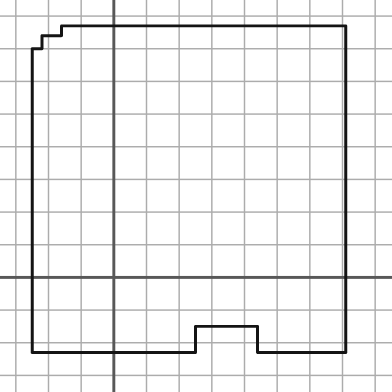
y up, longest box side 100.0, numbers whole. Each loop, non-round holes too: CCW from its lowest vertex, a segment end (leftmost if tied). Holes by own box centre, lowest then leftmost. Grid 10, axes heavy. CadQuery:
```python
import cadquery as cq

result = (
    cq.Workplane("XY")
    .moveTo(-25.0, -23.0)
    .lineTo(25.0, -23.0)
    .lineTo(25.0, -15.0)
    .lineTo(44.0, -15.0)
    .lineTo(44.0, -23.0)
    .lineTo(71.0, -23.0)
    .lineTo(71.0, 77.0)
    .lineTo(-16.0, 77.0)
    .lineTo(-16.0, 74.0)
    .lineTo(-22.0, 74.0)
    .lineTo(-22.0, 70.0)
    .lineTo(-25.0, 70.0)
    .close()
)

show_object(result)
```